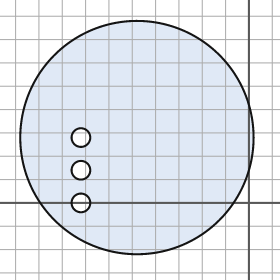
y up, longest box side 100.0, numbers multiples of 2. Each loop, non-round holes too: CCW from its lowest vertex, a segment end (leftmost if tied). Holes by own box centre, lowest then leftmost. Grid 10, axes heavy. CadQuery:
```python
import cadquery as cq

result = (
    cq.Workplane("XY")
    .moveTo(-48.0, 28.0)
    .circle(50.0)
    .moveTo(-72.0, 0.0)
    .circle(4.0)
    .moveTo(-72.0, 14.0)
    .circle(4.0)
    .moveTo(-72.0, 28.0)
    .circle(4.0)
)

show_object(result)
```